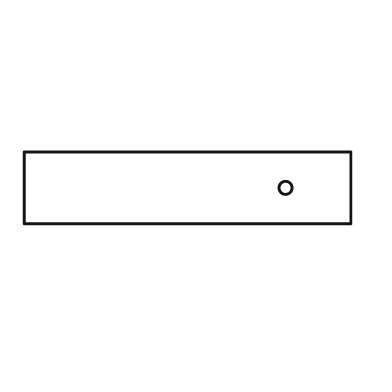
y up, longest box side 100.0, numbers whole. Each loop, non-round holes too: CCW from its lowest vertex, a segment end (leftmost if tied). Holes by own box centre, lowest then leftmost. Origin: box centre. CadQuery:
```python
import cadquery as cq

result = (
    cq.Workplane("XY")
    .moveTo(-50.0, -11.0)
    .lineTo(50.0, -11.0)
    .lineTo(50.0, 11.0)
    .lineTo(-50.0, 11.0)
    .close()
    .moveTo(30.0, 0.0)
    .circle(2.0)
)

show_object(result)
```